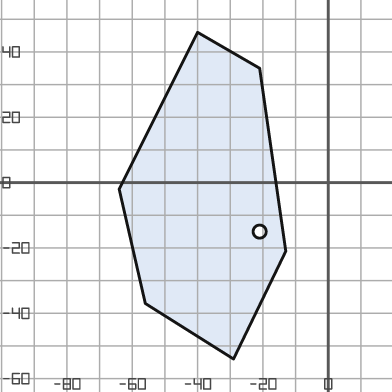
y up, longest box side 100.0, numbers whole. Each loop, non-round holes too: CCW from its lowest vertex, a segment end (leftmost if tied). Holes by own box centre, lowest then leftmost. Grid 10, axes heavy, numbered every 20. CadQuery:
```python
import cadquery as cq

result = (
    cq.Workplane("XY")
    .moveTo(-29.0, -54.0)
    .lineTo(-13.0, -21.0)
    .lineTo(-21.0, 35.0)
    .lineTo(-40.0, 46.0)
    .lineTo(-64.0, -2.0)
    .lineTo(-56.0, -37.0)
    .close()
    .moveTo(-21.0, -15.0)
    .circle(2.0)
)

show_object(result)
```